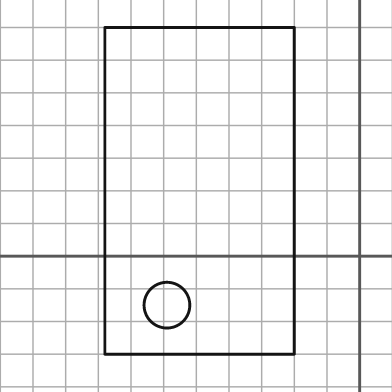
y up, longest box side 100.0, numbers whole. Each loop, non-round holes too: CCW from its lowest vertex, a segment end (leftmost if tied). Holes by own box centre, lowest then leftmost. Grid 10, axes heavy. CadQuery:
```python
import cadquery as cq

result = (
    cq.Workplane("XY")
    .moveTo(-78.0, -30.0)
    .lineTo(-20.0, -30.0)
    .lineTo(-20.0, 70.0)
    .lineTo(-78.0, 70.0)
    .close()
    .moveTo(-59.0, -15.0)
    .circle(7.0)
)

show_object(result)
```